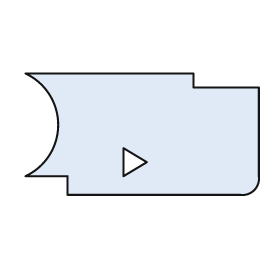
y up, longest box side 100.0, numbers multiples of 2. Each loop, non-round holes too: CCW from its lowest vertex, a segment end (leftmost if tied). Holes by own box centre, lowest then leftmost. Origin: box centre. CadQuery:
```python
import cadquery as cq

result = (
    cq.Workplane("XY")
    .moveTo(-32.0, -26.0)
    .lineTo(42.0, -26.0)
    .threePointArc((48.0, -24.0), (50.0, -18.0))
    .lineTo(50.0, 20.0)
    .lineTo(22.0, 20.0)
    .lineTo(22.0, 26.0)
    .lineTo(-50.0, 26.0)
    .threePointArc((-36.0, 4.0), (-50.0, -18.0))
    .lineTo(-32.0, -18.0)
    .close()
    .moveTo(-8.0, -18.0)
    .lineTo(2.0, -12.0)
    .lineTo(-8.0, -6.0)
    .close()
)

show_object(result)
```